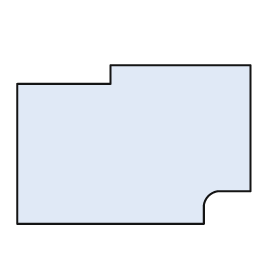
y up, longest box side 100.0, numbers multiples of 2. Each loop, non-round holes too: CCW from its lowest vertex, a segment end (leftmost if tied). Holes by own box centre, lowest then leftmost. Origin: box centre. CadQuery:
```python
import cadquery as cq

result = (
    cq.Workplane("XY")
    .moveTo(-50.0, -34.0)
    .lineTo(30.0, -34.0)
    .lineTo(30.0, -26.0)
    .threePointArc((32.0, -22.0), (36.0, -20.0))
    .lineTo(50.0, -20.0)
    .lineTo(50.0, 34.0)
    .lineTo(-10.0, 34.0)
    .lineTo(-10.0, 26.0)
    .lineTo(-50.0, 26.0)
    .close()
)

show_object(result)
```